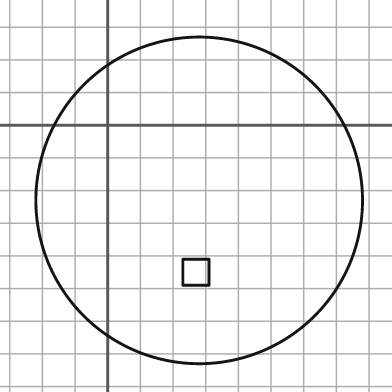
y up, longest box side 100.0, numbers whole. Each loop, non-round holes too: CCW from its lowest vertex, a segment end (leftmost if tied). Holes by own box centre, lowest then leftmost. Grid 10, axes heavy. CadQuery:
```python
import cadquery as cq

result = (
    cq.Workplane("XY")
    .moveTo(28.0, -23.0)
    .circle(50.0)
    .moveTo(23.0, -49.0)
    .lineTo(31.0, -49.0)
    .lineTo(31.0, -41.0)
    .lineTo(23.0, -41.0)
    .close()
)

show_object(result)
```